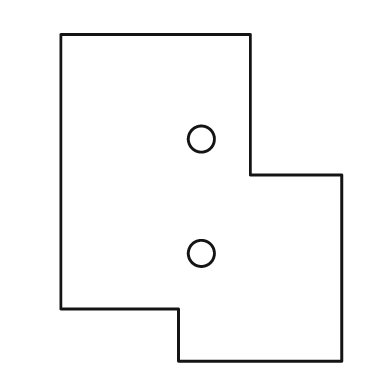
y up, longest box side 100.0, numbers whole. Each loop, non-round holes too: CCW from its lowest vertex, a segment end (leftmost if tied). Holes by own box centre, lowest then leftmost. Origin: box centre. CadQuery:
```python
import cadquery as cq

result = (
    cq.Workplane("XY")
    .moveTo(-7.0, -50.0)
    .lineTo(43.0, -50.0)
    .lineTo(43.0, 7.0)
    .lineTo(15.0, 7.0)
    .lineTo(15.0, 50.0)
    .lineTo(-43.0, 50.0)
    .lineTo(-43.0, -34.0)
    .lineTo(-7.0, -34.0)
    .close()
    .moveTo(0.0, -17.0)
    .circle(4.0)
    .moveTo(0.0, 18.0)
    .circle(4.0)
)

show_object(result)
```